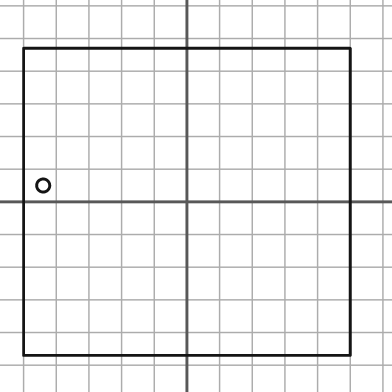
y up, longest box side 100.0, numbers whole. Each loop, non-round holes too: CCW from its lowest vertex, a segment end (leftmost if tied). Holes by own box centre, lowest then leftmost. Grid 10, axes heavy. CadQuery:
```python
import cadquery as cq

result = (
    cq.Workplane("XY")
    .moveTo(-50.0, -47.0)
    .lineTo(50.0, -47.0)
    .lineTo(50.0, 47.0)
    .lineTo(-50.0, 47.0)
    .close()
    .moveTo(-44.0, 5.0)
    .circle(2.0)
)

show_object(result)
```